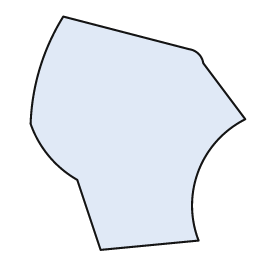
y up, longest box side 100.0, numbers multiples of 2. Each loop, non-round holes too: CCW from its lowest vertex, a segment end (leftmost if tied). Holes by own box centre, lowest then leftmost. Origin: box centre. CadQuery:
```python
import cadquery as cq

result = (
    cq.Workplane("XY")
    .moveTo(-16.0, -50.0)
    .lineTo(26.0, -46.0)
    .threePointArc((26.0, -16.0), (46.0, 6.0))
    .lineTo(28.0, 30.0)
    .threePointArc((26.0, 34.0), (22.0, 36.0))
    .lineTo(-32.0, 50.0)
    .threePointArc((-42.0, 28.0), (-46.0, 4.0))
    .threePointArc((-38.0, -10.0), (-26.0, -20.0))
    .close()
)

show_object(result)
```